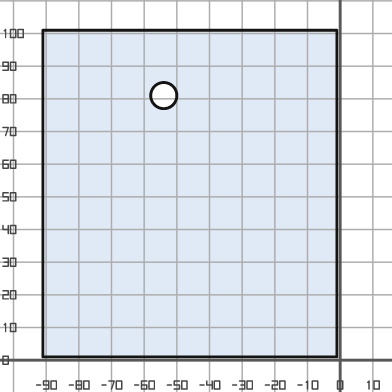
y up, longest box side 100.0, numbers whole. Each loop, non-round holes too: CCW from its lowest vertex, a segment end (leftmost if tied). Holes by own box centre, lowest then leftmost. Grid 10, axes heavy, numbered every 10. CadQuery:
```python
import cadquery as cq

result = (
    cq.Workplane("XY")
    .moveTo(-91.0, 1.0)
    .lineTo(-1.0, 1.0)
    .lineTo(-1.0, 101.0)
    .lineTo(-91.0, 101.0)
    .close()
    .moveTo(-54.0, 81.0)
    .circle(4.0)
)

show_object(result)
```